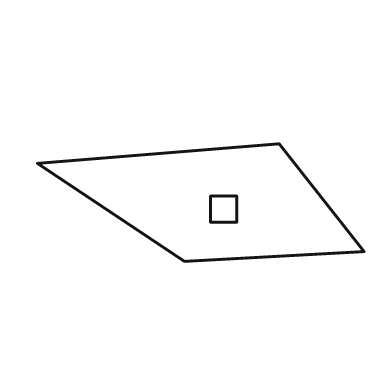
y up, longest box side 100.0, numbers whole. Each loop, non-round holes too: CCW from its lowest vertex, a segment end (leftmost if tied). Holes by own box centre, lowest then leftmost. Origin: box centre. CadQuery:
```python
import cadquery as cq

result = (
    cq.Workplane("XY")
    .moveTo(-5.0, -18.0)
    .lineTo(50.0, -15.0)
    .lineTo(24.0, 18.0)
    .lineTo(-50.0, 12.0)
    .close()
    .moveTo(3.0, -6.0)
    .lineTo(11.0, -6.0)
    .lineTo(11.0, 2.0)
    .lineTo(3.0, 2.0)
    .close()
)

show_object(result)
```